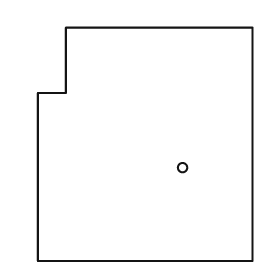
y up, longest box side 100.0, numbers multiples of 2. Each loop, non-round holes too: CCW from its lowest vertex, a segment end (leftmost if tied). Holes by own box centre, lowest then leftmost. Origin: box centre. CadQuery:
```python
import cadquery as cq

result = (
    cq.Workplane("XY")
    .moveTo(-46.0, -50.0)
    .lineTo(46.0, -50.0)
    .lineTo(46.0, 50.0)
    .lineTo(-34.0, 50.0)
    .lineTo(-34.0, 22.0)
    .lineTo(-46.0, 22.0)
    .close()
    .moveTo(16.0, -10.0)
    .circle(2.0)
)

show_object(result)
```